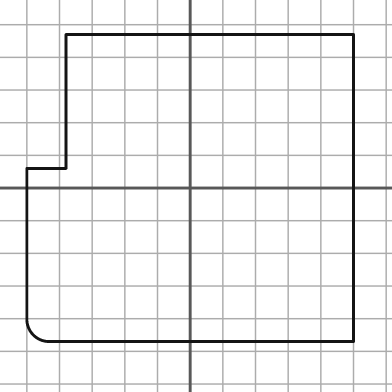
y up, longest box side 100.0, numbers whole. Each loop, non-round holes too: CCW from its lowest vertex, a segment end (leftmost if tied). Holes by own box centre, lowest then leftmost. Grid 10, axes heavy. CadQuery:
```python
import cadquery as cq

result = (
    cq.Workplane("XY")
    .moveTo(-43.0, -47.0)
    .lineTo(50.0, -47.0)
    .lineTo(50.0, 47.0)
    .lineTo(-38.0, 47.0)
    .lineTo(-38.0, 6.0)
    .lineTo(-50.0, 6.0)
    .lineTo(-50.0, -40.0)
    .threePointArc((-48.0, -45.0), (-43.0, -47.0))
    .close()
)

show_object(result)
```